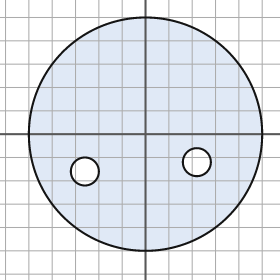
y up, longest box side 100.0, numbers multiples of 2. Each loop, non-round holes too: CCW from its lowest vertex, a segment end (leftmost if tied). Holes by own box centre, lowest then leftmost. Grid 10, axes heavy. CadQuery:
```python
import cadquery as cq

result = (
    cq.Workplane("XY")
    .moveTo(0.0, 0.0)
    .circle(50.0)
    .moveTo(-26.0, -16.0)
    .circle(6.0)
    .moveTo(22.0, -12.0)
    .circle(6.0)
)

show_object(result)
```